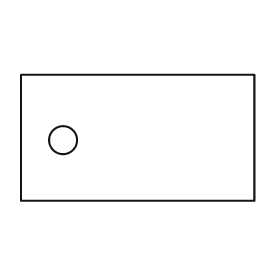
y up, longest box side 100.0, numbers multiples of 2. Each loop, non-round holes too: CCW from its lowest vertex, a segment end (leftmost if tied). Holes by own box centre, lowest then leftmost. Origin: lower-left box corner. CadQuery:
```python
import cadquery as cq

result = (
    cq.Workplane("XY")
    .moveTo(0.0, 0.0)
    .lineTo(100.0, 0.0)
    .lineTo(100.0, 54.0)
    .lineTo(0.0, 54.0)
    .close()
    .moveTo(18.0, 26.0)
    .circle(6.0)
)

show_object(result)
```